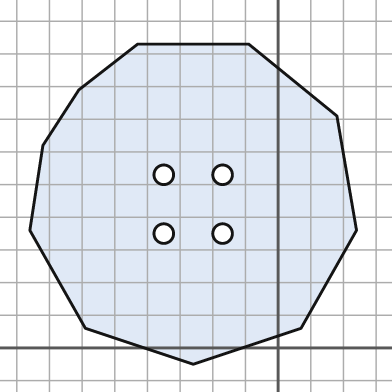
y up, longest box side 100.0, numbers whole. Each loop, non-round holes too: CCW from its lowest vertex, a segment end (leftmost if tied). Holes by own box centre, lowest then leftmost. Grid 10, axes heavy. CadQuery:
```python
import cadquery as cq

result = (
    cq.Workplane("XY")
    .moveTo(-26.0, -5.0)
    .lineTo(7.0, 6.0)
    .lineTo(24.0, 36.0)
    .lineTo(18.0, 71.0)
    .lineTo(-9.0, 93.0)
    .lineTo(-43.0, 93.0)
    .lineTo(-61.0, 79.0)
    .lineTo(-72.0, 62.0)
    .lineTo(-76.0, 36.0)
    .lineTo(-59.0, 6.0)
    .close()
    .moveTo(-35.0, 35.0)
    .circle(3.0)
    .moveTo(-17.0, 35.0)
    .circle(3.0)
    .moveTo(-35.0, 53.0)
    .circle(3.0)
    .moveTo(-17.0, 53.0)
    .circle(3.0)
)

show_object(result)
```